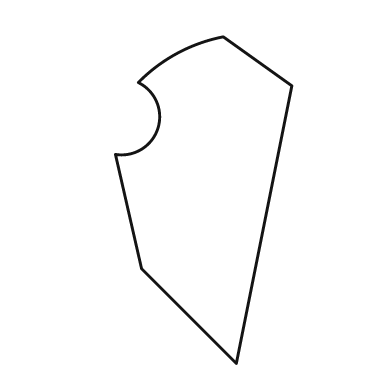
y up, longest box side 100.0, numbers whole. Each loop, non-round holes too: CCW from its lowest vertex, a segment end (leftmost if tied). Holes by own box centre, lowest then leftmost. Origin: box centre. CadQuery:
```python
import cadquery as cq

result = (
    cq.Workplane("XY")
    .moveTo(10.0, -50.0)
    .lineTo(27.0, 35.0)
    .lineTo(6.0, 50.0)
    .threePointArc((-8.0, 45.0), (-20.0, 36.0))
    .threePointArc((-14.0, 22.0), (-27.0, 14.0))
    .lineTo(-19.0, -21.0)
    .close()
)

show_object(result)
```